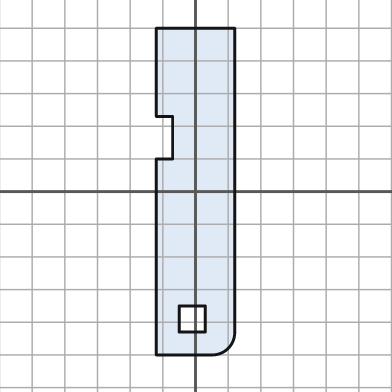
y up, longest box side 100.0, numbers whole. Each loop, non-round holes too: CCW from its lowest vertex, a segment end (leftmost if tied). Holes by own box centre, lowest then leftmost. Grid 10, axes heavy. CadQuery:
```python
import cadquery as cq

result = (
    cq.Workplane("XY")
    .moveTo(-12.0, -50.0)
    .lineTo(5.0, -50.0)
    .threePointArc((10.0, -48.0), (12.0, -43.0))
    .lineTo(12.0, 50.0)
    .lineTo(-12.0, 50.0)
    .lineTo(-12.0, 23.0)
    .lineTo(-7.0, 23.0)
    .lineTo(-7.0, 10.0)
    .lineTo(-12.0, 10.0)
    .close()
    .moveTo(-5.0, -43.0)
    .lineTo(3.0, -43.0)
    .lineTo(3.0, -35.0)
    .lineTo(-5.0, -35.0)
    .close()
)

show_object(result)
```